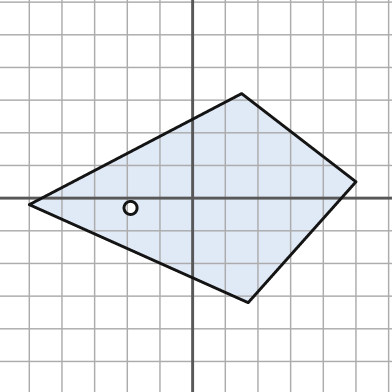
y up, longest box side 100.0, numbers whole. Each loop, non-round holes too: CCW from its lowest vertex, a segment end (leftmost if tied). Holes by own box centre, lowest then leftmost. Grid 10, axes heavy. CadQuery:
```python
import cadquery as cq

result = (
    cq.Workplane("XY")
    .moveTo(17.0, -32.0)
    .lineTo(50.0, 5.0)
    .lineTo(15.0, 32.0)
    .lineTo(-50.0, -2.0)
    .close()
    .moveTo(-19.0, -3.0)
    .circle(2.0)
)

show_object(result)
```